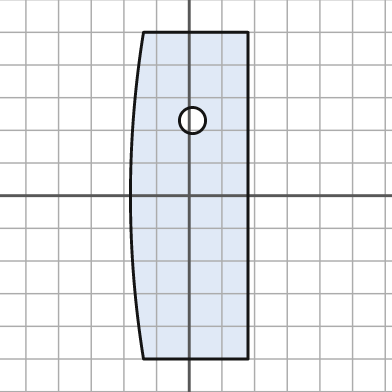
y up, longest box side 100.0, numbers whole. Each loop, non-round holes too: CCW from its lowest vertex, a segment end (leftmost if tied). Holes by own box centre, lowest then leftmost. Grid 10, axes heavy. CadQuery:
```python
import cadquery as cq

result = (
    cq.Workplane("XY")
    .moveTo(-14.0, -50.0)
    .lineTo(18.0, -50.0)
    .lineTo(18.0, 50.0)
    .lineTo(-14.0, 50.0)
    .threePointArc((-18.0, 0.0), (-14.0, -50.0))
    .close()
    .moveTo(1.0, 23.0)
    .circle(4.0)
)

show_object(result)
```